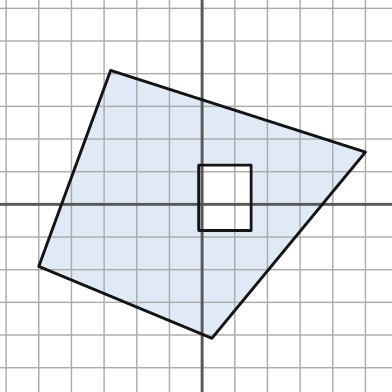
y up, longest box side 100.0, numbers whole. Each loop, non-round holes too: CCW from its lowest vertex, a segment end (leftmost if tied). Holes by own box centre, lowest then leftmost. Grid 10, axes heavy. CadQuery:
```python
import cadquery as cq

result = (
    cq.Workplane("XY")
    .moveTo(3.0, -41.0)
    .lineTo(50.0, 16.0)
    .lineTo(-28.0, 41.0)
    .lineTo(-50.0, -19.0)
    .close()
    .moveTo(-1.0, -8.0)
    .lineTo(15.0, -8.0)
    .lineTo(15.0, 12.0)
    .lineTo(-1.0, 12.0)
    .close()
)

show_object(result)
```